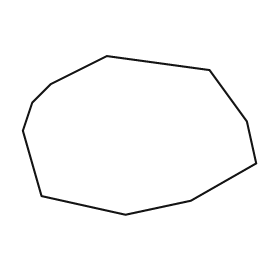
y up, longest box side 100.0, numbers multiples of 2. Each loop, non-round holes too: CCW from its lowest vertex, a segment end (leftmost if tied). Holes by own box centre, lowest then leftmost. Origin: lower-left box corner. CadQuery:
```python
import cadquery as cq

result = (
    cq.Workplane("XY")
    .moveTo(44.0, 0.0)
    .lineTo(72.0, 6.0)
    .lineTo(100.0, 22.0)
    .lineTo(96.0, 40.0)
    .lineTo(80.0, 62.0)
    .lineTo(36.0, 68.0)
    .lineTo(12.0, 56.0)
    .lineTo(4.0, 48.0)
    .lineTo(0.0, 36.0)
    .lineTo(8.0, 8.0)
    .close()
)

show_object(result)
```